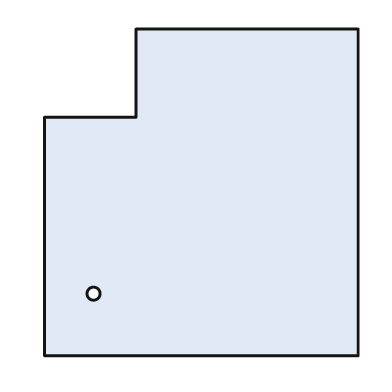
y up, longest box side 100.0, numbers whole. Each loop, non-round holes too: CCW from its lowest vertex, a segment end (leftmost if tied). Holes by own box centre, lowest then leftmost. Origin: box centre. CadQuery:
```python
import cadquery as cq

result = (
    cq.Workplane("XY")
    .moveTo(-48.0, -50.0)
    .lineTo(48.0, -50.0)
    .lineTo(48.0, 50.0)
    .lineTo(-20.0, 50.0)
    .lineTo(-20.0, 23.0)
    .lineTo(-48.0, 23.0)
    .close()
    .moveTo(-33.0, -31.0)
    .circle(2.0)
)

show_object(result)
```